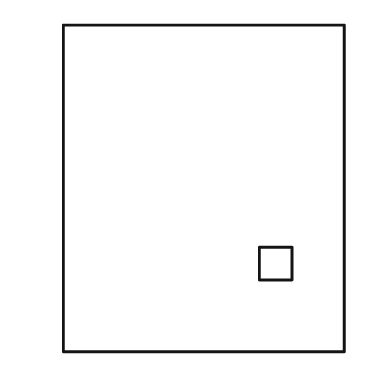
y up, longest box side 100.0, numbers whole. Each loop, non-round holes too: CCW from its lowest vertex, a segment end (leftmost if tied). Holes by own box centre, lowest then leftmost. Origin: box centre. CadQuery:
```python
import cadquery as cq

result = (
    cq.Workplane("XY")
    .moveTo(-43.0, -50.0)
    .lineTo(43.0, -50.0)
    .lineTo(43.0, 50.0)
    .lineTo(-43.0, 50.0)
    .close()
    .moveTo(17.0, -28.0)
    .lineTo(27.0, -28.0)
    .lineTo(27.0, -18.0)
    .lineTo(17.0, -18.0)
    .close()
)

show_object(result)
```